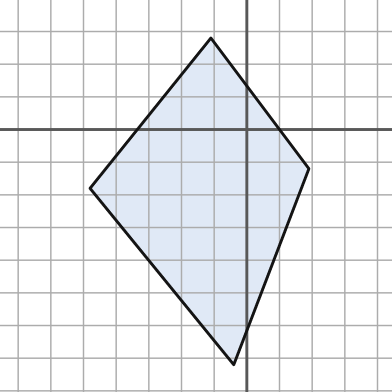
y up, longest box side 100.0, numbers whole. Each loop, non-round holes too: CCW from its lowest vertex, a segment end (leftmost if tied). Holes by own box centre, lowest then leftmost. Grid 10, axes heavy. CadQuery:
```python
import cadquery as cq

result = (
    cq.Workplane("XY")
    .moveTo(-4.0, -72.0)
    .lineTo(19.0, -12.0)
    .lineTo(-11.0, 28.0)
    .lineTo(-48.0, -18.0)
    .close()
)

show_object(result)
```